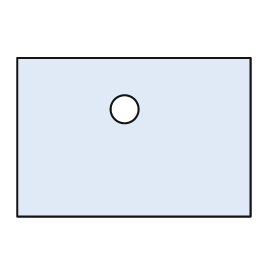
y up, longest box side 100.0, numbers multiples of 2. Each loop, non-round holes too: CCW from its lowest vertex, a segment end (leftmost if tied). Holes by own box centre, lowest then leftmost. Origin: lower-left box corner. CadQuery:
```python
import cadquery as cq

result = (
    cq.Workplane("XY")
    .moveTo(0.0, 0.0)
    .lineTo(100.0, 0.0)
    .lineTo(100.0, 68.0)
    .lineTo(0.0, 68.0)
    .close()
    .moveTo(46.0, 46.0)
    .circle(6.0)
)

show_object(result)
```